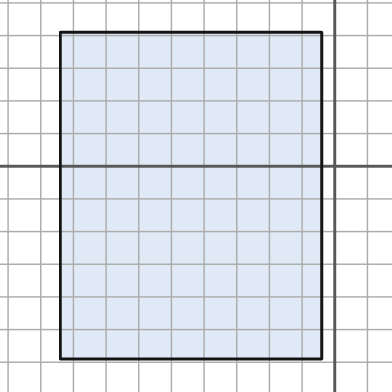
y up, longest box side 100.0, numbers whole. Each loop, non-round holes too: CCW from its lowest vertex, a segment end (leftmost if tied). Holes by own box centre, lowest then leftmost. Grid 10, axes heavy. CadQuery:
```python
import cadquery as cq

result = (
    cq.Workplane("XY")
    .moveTo(-84.0, -59.0)
    .lineTo(-4.0, -59.0)
    .lineTo(-4.0, 41.0)
    .lineTo(-84.0, 41.0)
    .close()
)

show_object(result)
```